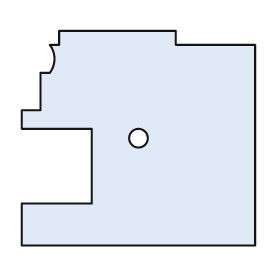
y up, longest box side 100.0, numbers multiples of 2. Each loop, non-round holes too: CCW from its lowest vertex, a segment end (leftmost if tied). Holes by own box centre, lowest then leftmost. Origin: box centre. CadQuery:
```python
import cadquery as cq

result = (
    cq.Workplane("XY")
    .moveTo(-50.0, -46.0)
    .lineTo(50.0, -46.0)
    .lineTo(50.0, 40.0)
    .lineTo(16.0, 40.0)
    .lineTo(16.0, 46.0)
    .lineTo(-34.0, 46.0)
    .lineTo(-34.0, 40.0)
    .lineTo(-38.0, 40.0)
    .threePointArc((-36.0, 34.0), (-38.0, 28.0))
    .lineTo(-42.0, 28.0)
    .lineTo(-42.0, 12.0)
    .lineTo(-50.0, 12.0)
    .lineTo(-50.0, 4.0)
    .lineTo(-20.0, 4.0)
    .lineTo(-20.0, -28.0)
    .lineTo(-50.0, -28.0)
    .close()
    .moveTo(0.0, 0.0)
    .circle(4.0)
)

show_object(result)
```